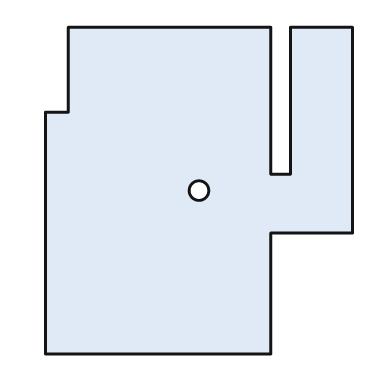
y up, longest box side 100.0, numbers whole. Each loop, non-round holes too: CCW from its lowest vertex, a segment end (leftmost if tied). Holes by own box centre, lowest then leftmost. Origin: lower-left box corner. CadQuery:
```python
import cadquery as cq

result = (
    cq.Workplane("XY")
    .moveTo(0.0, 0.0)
    .lineTo(69.0, 0.0)
    .lineTo(69.0, 37.0)
    .lineTo(94.0, 37.0)
    .lineTo(94.0, 100.0)
    .lineTo(75.0, 100.0)
    .lineTo(75.0, 55.0)
    .lineTo(69.0, 55.0)
    .lineTo(69.0, 100.0)
    .lineTo(7.0, 100.0)
    .lineTo(7.0, 74.0)
    .lineTo(0.0, 74.0)
    .close()
    .moveTo(47.0, 50.0)
    .circle(3.0)
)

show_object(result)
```